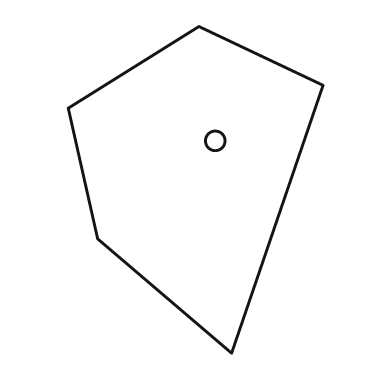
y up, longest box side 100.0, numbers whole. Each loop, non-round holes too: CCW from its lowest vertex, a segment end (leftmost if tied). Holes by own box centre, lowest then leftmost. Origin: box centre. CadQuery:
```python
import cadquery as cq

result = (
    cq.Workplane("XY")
    .moveTo(11.0, -50.0)
    .lineTo(39.0, 32.0)
    .lineTo(1.0, 50.0)
    .lineTo(-39.0, 25.0)
    .lineTo(-30.0, -15.0)
    .close()
    .moveTo(6.0, 15.0)
    .circle(3.0)
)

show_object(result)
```